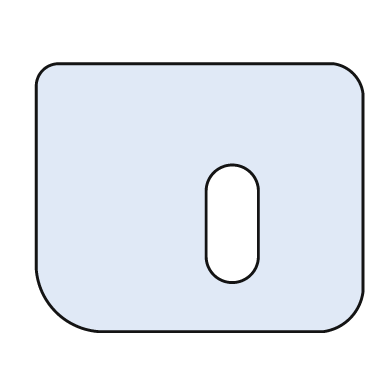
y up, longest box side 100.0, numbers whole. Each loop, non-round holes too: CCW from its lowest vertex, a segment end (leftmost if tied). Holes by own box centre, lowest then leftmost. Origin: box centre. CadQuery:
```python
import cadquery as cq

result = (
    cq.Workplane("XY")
    .moveTo(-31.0, -41.0)
    .lineTo(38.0, -41.0)
    .threePointArc((46.0, -37.0), (50.0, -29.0))
    .lineTo(50.0, 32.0)
    .threePointArc((47.0, 38.0), (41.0, 41.0))
    .lineTo(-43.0, 41.0)
    .threePointArc((-48.0, 39.0), (-50.0, 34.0))
    .lineTo(-50.0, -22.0)
    .threePointArc((-44.0, -35.0), (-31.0, -41.0))
    .close()
    .moveTo(2.0, -18.0)
    .threePointArc((10.0, -26.0), (18.0, -18.0))
    .lineTo(18.0, 2.0)
    .threePointArc((10.0, 10.0), (2.0, 2.0))
    .close()
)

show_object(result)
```